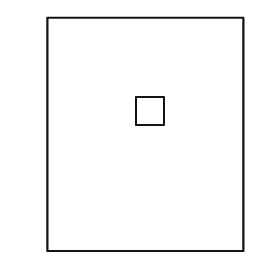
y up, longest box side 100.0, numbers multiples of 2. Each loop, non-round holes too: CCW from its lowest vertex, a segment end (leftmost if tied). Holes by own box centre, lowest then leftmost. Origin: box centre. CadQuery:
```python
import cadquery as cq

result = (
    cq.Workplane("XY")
    .moveTo(-42.0, -50.0)
    .lineTo(42.0, -50.0)
    .lineTo(42.0, 50.0)
    .lineTo(-42.0, 50.0)
    .close()
    .moveTo(-4.0, 4.0)
    .lineTo(8.0, 4.0)
    .lineTo(8.0, 16.0)
    .lineTo(-4.0, 16.0)
    .close()
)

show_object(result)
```